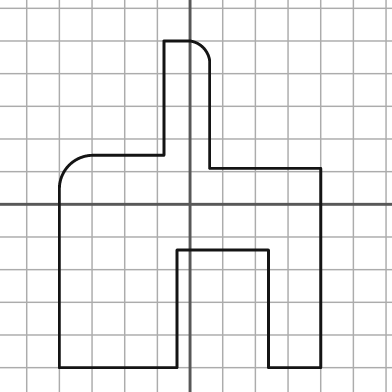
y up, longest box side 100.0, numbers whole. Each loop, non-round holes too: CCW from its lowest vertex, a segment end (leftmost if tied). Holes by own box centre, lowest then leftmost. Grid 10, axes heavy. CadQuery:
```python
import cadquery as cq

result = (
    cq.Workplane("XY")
    .moveTo(-40.0, -50.0)
    .lineTo(-4.0, -50.0)
    .lineTo(-4.0, -14.0)
    .lineTo(24.0, -14.0)
    .lineTo(24.0, -50.0)
    .lineTo(40.0, -50.0)
    .lineTo(40.0, 11.0)
    .lineTo(6.0, 11.0)
    .lineTo(6.0, 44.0)
    .threePointArc((4.0, 48.0), (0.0, 50.0))
    .lineTo(-8.0, 50.0)
    .lineTo(-8.0, 15.0)
    .lineTo(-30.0, 15.0)
    .threePointArc((-37.0, 12.0), (-40.0, 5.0))
    .close()
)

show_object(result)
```